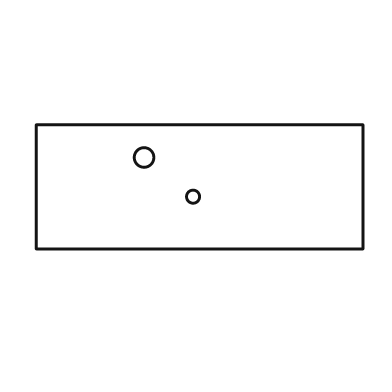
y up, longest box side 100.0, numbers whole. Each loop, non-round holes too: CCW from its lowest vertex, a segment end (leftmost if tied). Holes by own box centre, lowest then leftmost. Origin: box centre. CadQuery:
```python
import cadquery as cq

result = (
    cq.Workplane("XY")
    .moveTo(-50.0, -19.0)
    .lineTo(50.0, -19.0)
    .lineTo(50.0, 19.0)
    .lineTo(-50.0, 19.0)
    .close()
    .moveTo(-2.0, -3.0)
    .circle(2.0)
    .moveTo(-17.0, 9.0)
    .circle(3.0)
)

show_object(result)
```